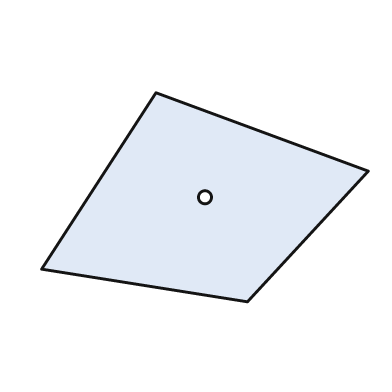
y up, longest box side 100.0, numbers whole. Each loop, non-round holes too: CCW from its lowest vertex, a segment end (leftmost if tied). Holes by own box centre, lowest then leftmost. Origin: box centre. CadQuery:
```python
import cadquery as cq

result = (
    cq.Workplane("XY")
    .moveTo(13.0, -32.0)
    .lineTo(50.0, 8.0)
    .lineTo(-15.0, 32.0)
    .lineTo(-50.0, -22.0)
    .close()
    .moveTo(0.0, 0.0)
    .circle(2.0)
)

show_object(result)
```